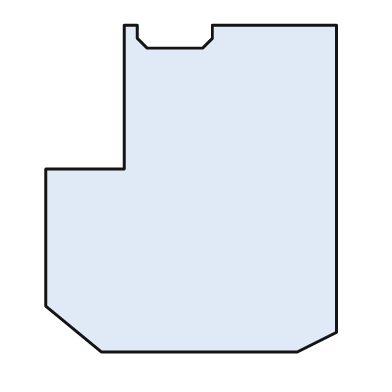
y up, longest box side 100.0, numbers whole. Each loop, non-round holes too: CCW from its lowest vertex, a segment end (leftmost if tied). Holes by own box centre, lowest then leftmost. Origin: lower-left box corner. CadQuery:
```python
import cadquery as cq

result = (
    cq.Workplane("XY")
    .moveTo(17.0, 0.0)
    .lineTo(77.0, 0.0)
    .lineTo(89.0, 6.0)
    .lineTo(89.0, 100.0)
    .lineTo(51.0, 100.0)
    .lineTo(51.0, 96.0)
    .lineTo(48.0, 93.0)
    .lineTo(31.0, 93.0)
    .lineTo(28.0, 96.0)
    .lineTo(28.0, 100.0)
    .lineTo(24.0, 100.0)
    .lineTo(24.0, 56.0)
    .lineTo(0.0, 56.0)
    .lineTo(0.0, 14.0)
    .close()
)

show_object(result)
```